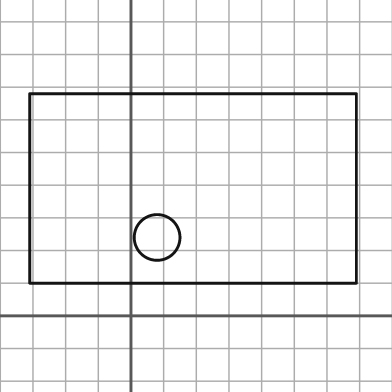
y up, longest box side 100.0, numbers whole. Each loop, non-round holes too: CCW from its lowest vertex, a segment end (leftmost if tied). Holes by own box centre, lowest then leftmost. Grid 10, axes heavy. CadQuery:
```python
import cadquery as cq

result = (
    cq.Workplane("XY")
    .moveTo(-31.0, 10.0)
    .lineTo(69.0, 10.0)
    .lineTo(69.0, 68.0)
    .lineTo(-31.0, 68.0)
    .close()
    .moveTo(8.0, 24.0)
    .circle(7.0)
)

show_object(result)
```